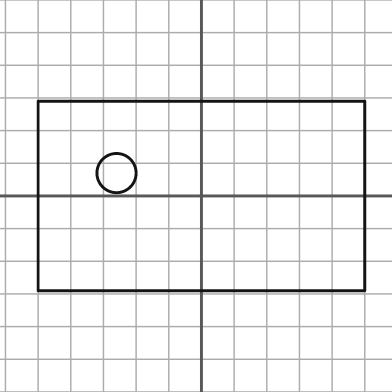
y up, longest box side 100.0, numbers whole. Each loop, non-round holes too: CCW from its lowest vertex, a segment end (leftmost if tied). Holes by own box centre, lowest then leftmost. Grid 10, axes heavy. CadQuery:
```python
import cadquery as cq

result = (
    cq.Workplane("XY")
    .moveTo(-50.0, -29.0)
    .lineTo(50.0, -29.0)
    .lineTo(50.0, 29.0)
    .lineTo(-50.0, 29.0)
    .close()
    .moveTo(-26.0, 7.0)
    .circle(6.0)
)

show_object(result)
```